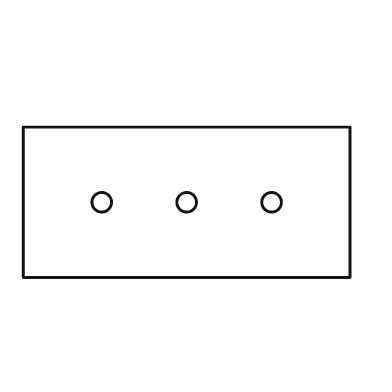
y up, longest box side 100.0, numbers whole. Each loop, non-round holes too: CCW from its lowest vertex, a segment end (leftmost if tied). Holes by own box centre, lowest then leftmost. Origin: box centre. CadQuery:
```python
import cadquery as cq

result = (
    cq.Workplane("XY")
    .moveTo(-50.0, -23.0)
    .lineTo(50.0, -23.0)
    .lineTo(50.0, 23.0)
    .lineTo(-50.0, 23.0)
    .close()
    .moveTo(-26.0, 0.0)
    .circle(3.0)
    .moveTo(0.0, 0.0)
    .circle(3.0)
    .moveTo(26.0, 0.0)
    .circle(3.0)
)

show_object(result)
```